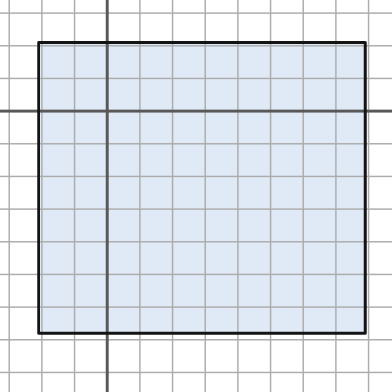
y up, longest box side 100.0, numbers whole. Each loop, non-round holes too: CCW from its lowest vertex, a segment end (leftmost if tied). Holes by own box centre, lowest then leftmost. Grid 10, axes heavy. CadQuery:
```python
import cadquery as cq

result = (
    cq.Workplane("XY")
    .moveTo(-21.0, -68.0)
    .lineTo(79.0, -68.0)
    .lineTo(79.0, 21.0)
    .lineTo(-21.0, 21.0)
    .close()
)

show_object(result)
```